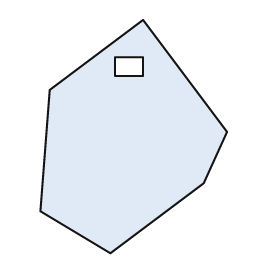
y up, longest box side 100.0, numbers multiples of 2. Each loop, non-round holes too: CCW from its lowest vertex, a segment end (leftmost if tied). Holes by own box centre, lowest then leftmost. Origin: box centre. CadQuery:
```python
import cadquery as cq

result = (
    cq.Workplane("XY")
    .moveTo(-10.0, -50.0)
    .lineTo(30.0, -20.0)
    .lineTo(40.0, 2.0)
    .lineTo(4.0, 50.0)
    .lineTo(-36.0, 20.0)
    .lineTo(-40.0, -32.0)
    .close()
    .moveTo(-8.0, 26.0)
    .lineTo(4.0, 26.0)
    .lineTo(4.0, 34.0)
    .lineTo(-8.0, 34.0)
    .close()
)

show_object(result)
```